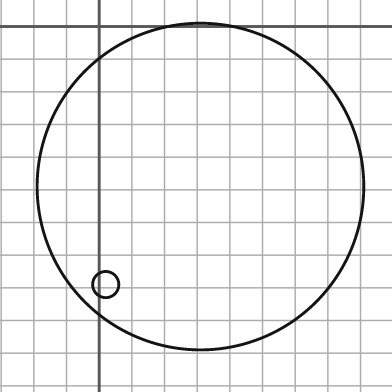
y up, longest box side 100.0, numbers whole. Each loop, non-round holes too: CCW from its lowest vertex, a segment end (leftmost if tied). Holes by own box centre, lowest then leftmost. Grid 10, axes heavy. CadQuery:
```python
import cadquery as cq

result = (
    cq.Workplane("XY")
    .moveTo(31.0, -49.0)
    .circle(50.0)
    .moveTo(2.0, -79.0)
    .circle(4.0)
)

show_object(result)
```